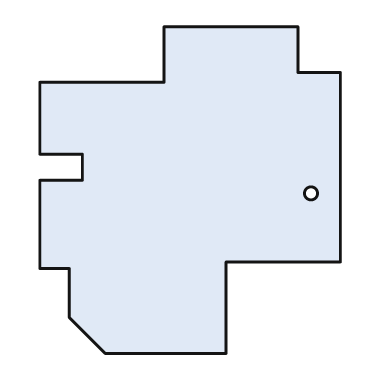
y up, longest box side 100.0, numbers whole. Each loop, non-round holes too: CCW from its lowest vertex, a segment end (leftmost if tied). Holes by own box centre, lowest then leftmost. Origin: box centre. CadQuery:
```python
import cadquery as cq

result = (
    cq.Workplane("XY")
    .moveTo(-26.0, -50.0)
    .lineTo(11.0, -50.0)
    .lineTo(11.0, -22.0)
    .lineTo(46.0, -22.0)
    .lineTo(46.0, 36.0)
    .lineTo(33.0, 36.0)
    .lineTo(33.0, 50.0)
    .lineTo(-8.0, 50.0)
    .lineTo(-8.0, 33.0)
    .lineTo(-46.0, 33.0)
    .lineTo(-46.0, 11.0)
    .lineTo(-33.0, 11.0)
    .lineTo(-33.0, 3.0)
    .lineTo(-46.0, 3.0)
    .lineTo(-46.0, -24.0)
    .lineTo(-37.0, -24.0)
    .lineTo(-37.0, -39.0)
    .close()
    .moveTo(37.0, -1.0)
    .circle(2.0)
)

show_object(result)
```